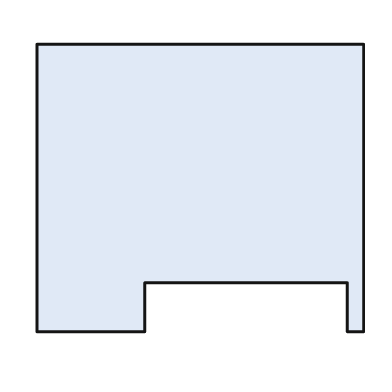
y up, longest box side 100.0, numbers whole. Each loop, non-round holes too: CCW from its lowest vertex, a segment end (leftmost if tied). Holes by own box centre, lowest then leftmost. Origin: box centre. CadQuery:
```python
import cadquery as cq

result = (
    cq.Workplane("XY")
    .moveTo(-50.0, -44.0)
    .lineTo(-17.0, -44.0)
    .lineTo(-17.0, -29.0)
    .lineTo(45.0, -29.0)
    .lineTo(45.0, -44.0)
    .lineTo(50.0, -44.0)
    .lineTo(50.0, 44.0)
    .lineTo(-50.0, 44.0)
    .close()
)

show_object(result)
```